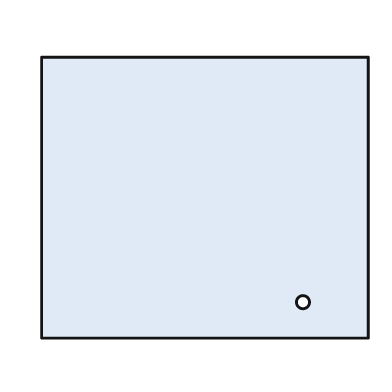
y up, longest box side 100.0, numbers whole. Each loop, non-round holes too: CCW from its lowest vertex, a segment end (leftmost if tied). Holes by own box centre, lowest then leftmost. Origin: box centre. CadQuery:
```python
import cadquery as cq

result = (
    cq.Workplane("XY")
    .moveTo(-50.0, -43.0)
    .lineTo(50.0, -43.0)
    .lineTo(50.0, 43.0)
    .lineTo(-50.0, 43.0)
    .close()
    .moveTo(30.0, -32.0)
    .circle(2.0)
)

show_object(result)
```